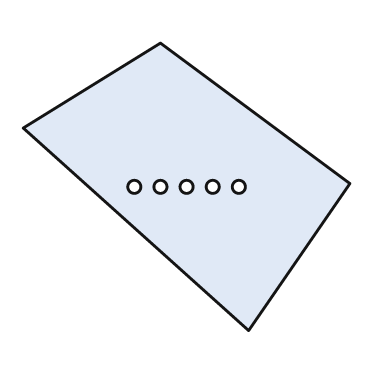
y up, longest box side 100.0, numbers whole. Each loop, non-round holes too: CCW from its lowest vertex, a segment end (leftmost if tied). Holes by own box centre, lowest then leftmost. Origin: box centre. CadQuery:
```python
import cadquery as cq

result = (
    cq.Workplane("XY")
    .moveTo(19.0, -44.0)
    .lineTo(50.0, 1.0)
    .lineTo(-8.0, 44.0)
    .lineTo(-50.0, 18.0)
    .close()
    .moveTo(-16.0, 0.0)
    .circle(2.0)
    .moveTo(-8.0, 0.0)
    .circle(2.0)
    .moveTo(0.0, 0.0)
    .circle(2.0)
    .moveTo(8.0, 0.0)
    .circle(2.0)
    .moveTo(16.0, 0.0)
    .circle(2.0)
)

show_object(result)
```